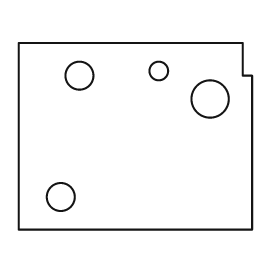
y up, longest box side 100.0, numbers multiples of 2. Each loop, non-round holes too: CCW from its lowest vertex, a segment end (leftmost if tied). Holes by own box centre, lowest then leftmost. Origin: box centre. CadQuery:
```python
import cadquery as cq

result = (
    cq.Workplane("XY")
    .moveTo(-50.0, -40.0)
    .lineTo(50.0, -40.0)
    .lineTo(50.0, 26.0)
    .lineTo(46.0, 26.0)
    .lineTo(46.0, 40.0)
    .lineTo(-50.0, 40.0)
    .close()
    .moveTo(-32.0, -26.0)
    .circle(6.0)
    .moveTo(32.0, 16.0)
    .circle(8.0)
    .moveTo(-24.0, 26.0)
    .circle(6.0)
    .moveTo(10.0, 28.0)
    .circle(4.0)
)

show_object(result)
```